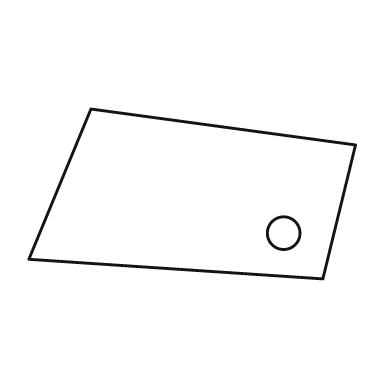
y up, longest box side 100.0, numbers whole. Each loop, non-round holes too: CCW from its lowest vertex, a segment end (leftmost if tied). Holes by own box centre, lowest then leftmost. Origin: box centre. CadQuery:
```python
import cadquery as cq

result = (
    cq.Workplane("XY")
    .moveTo(40.0, -26.0)
    .lineTo(50.0, 15.0)
    .lineTo(-31.0, 26.0)
    .lineTo(-50.0, -20.0)
    .close()
    .moveTo(28.0, -12.0)
    .circle(5.0)
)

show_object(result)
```